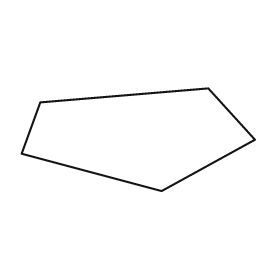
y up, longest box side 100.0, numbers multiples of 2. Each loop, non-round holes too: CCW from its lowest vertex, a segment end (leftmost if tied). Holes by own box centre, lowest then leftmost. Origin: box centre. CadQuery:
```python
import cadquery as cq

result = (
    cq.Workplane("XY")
    .moveTo(10.0, -22.0)
    .lineTo(50.0, 0.0)
    .lineTo(30.0, 22.0)
    .lineTo(-42.0, 16.0)
    .lineTo(-50.0, -6.0)
    .close()
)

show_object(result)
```